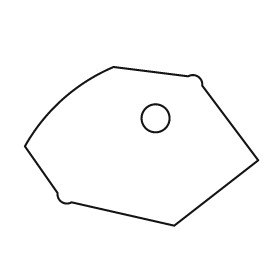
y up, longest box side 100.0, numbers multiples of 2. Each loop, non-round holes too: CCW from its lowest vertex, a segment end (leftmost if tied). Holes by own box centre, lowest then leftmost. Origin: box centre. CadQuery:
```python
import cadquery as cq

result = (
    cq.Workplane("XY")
    .moveTo(14.0, -34.0)
    .lineTo(50.0, -6.0)
    .lineTo(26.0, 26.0)
    .threePointArc((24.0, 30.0), (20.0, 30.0))
    .lineTo(-12.0, 34.0)
    .threePointArc((-34.0, 20.0), (-50.0, 0.0))
    .lineTo(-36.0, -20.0)
    .threePointArc((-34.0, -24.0), (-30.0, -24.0))
    .close()
    .moveTo(6.0, 12.0)
    .circle(6.0)
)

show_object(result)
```